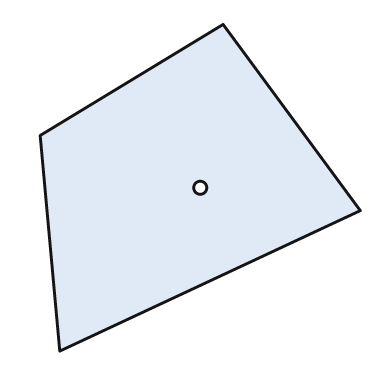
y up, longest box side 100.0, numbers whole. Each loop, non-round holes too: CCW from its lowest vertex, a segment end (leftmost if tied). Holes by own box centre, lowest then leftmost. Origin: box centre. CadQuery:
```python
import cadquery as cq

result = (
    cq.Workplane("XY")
    .moveTo(-43.0, -50.0)
    .lineTo(49.0, -7.0)
    .lineTo(7.0, 50.0)
    .lineTo(-49.0, 16.0)
    .close()
    .moveTo(0.0, 0.0)
    .circle(2.0)
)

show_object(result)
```